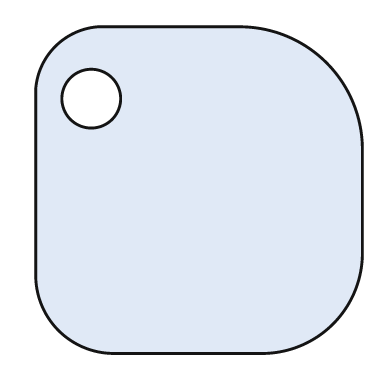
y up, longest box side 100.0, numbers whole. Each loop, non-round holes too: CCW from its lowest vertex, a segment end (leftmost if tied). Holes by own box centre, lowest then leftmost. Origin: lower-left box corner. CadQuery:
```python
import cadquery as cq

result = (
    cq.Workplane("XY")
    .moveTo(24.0, 0.0)
    .lineTo(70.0, 0.0)
    .threePointArc((91.0, 9.0), (100.0, 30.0))
    .lineTo(100.0, 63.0)
    .threePointArc((89.0, 89.0), (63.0, 100.0))
    .lineTo(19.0, 100.0)
    .threePointArc((6.0, 94.0), (0.0, 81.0))
    .lineTo(0.0, 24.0)
    .threePointArc((7.0, 7.0), (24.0, 0.0))
    .close()
    .moveTo(17.0, 78.0)
    .circle(9.0)
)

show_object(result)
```